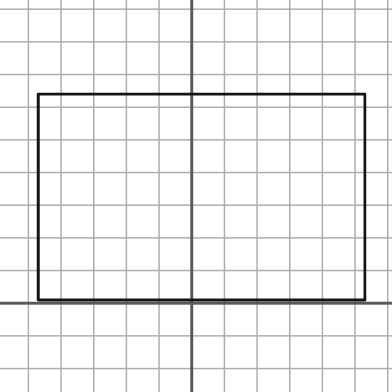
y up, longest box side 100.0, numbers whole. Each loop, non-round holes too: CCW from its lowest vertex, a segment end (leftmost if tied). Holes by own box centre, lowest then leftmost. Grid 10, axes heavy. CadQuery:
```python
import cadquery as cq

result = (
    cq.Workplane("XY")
    .moveTo(-47.0, 1.0)
    .lineTo(53.0, 1.0)
    .lineTo(53.0, 64.0)
    .lineTo(-47.0, 64.0)
    .close()
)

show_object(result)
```